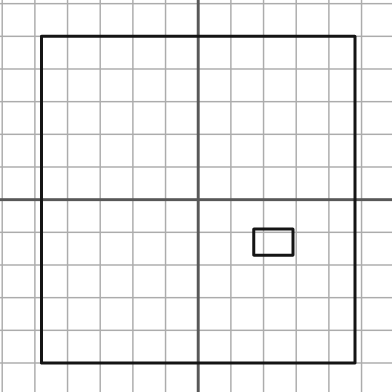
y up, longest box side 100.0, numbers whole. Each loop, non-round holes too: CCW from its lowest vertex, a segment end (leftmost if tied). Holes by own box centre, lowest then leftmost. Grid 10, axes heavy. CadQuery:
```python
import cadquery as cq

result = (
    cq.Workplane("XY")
    .moveTo(-48.0, -50.0)
    .lineTo(48.0, -50.0)
    .lineTo(48.0, 50.0)
    .lineTo(-48.0, 50.0)
    .close()
    .moveTo(17.0, -17.0)
    .lineTo(29.0, -17.0)
    .lineTo(29.0, -9.0)
    .lineTo(17.0, -9.0)
    .close()
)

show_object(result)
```